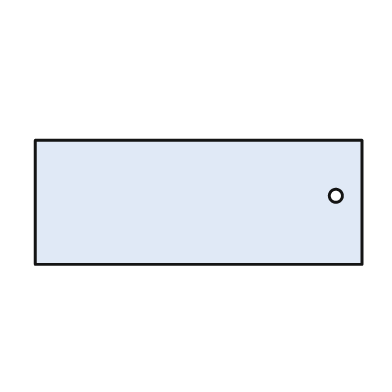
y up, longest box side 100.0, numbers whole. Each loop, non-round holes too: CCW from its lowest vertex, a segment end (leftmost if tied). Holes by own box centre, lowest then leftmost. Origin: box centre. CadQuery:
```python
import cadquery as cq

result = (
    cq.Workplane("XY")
    .moveTo(-50.0, -19.0)
    .lineTo(50.0, -19.0)
    .lineTo(50.0, 19.0)
    .lineTo(-50.0, 19.0)
    .close()
    .moveTo(42.0, 2.0)
    .circle(2.0)
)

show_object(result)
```